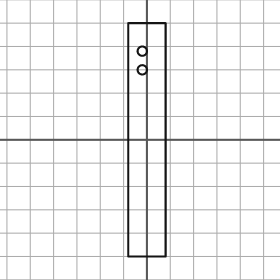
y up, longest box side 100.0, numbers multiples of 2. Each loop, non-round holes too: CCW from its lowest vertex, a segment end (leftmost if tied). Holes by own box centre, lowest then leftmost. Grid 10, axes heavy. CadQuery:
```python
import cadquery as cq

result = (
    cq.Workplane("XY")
    .moveTo(-8.0, -50.0)
    .lineTo(8.0, -50.0)
    .lineTo(8.0, 50.0)
    .lineTo(-8.0, 50.0)
    .close()
    .moveTo(-2.0, 30.0)
    .circle(2.0)
    .moveTo(-2.0, 38.0)
    .circle(2.0)
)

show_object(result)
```